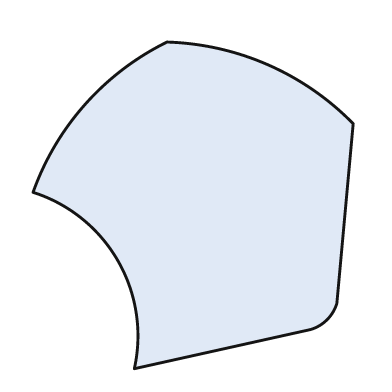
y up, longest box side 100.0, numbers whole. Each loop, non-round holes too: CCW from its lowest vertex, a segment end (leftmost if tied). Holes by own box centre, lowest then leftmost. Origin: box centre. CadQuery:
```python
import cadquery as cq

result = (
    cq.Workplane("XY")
    .moveTo(-18.0, -50.0)
    .lineTo(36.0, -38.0)
    .threePointArc((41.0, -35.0), (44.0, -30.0))
    .lineTo(49.0, 25.0)
    .threePointArc((23.0, 43.0), (-8.0, 50.0))
    .threePointArc((-33.0, 31.0), (-49.0, 4.0))
    .threePointArc((-23.0, -17.0), (-18.0, -50.0))
    .close()
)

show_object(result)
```